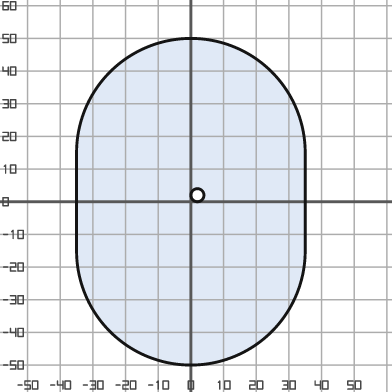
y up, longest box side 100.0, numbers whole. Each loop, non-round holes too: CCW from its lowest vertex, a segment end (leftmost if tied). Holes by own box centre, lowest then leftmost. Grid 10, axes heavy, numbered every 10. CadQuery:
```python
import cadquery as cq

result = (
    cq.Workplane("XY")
    .moveTo(-35.0, -15.0)
    .threePointArc((0.0, -50.0), (35.0, -15.0))
    .lineTo(35.0, 15.0)
    .threePointArc((0.0, 50.0), (-35.0, 15.0))
    .close()
    .moveTo(2.0, 2.0)
    .circle(2.0)
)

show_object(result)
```